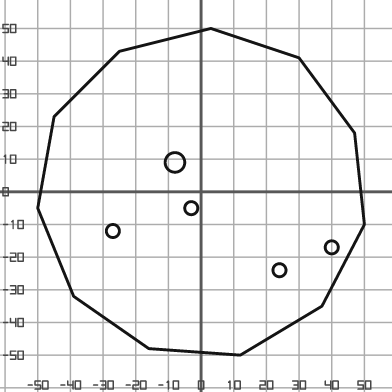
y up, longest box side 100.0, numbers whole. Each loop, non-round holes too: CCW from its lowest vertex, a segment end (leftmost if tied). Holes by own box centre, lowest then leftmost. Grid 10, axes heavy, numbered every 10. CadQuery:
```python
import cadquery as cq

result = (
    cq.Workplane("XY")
    .moveTo(12.0, -50.0)
    .lineTo(37.0, -35.0)
    .lineTo(50.0, -10.0)
    .lineTo(47.0, 18.0)
    .lineTo(30.0, 41.0)
    .lineTo(3.0, 50.0)
    .lineTo(-25.0, 43.0)
    .lineTo(-45.0, 23.0)
    .lineTo(-50.0, -5.0)
    .lineTo(-39.0, -32.0)
    .lineTo(-16.0, -48.0)
    .close()
    .moveTo(24.0, -24.0)
    .circle(2.0)
    .moveTo(40.0, -17.0)
    .circle(2.0)
    .moveTo(-27.0, -12.0)
    .circle(2.0)
    .moveTo(-3.0, -5.0)
    .circle(2.0)
    .moveTo(-8.0, 9.0)
    .circle(3.0)
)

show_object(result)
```